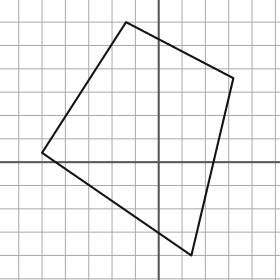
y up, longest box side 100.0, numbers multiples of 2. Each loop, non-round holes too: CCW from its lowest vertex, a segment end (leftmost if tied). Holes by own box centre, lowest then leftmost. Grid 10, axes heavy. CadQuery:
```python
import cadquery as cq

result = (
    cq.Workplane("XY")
    .moveTo(14.0, -40.0)
    .lineTo(32.0, 36.0)
    .lineTo(-14.0, 60.0)
    .lineTo(-50.0, 4.0)
    .close()
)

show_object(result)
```